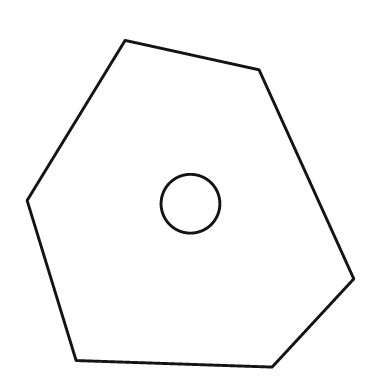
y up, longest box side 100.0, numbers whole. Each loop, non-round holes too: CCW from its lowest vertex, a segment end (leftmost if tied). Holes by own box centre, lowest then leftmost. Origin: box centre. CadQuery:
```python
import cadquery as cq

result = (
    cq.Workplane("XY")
    .moveTo(25.0, -50.0)
    .lineTo(50.0, -23.0)
    .lineTo(21.0, 41.0)
    .lineTo(-20.0, 50.0)
    .lineTo(-50.0, 1.0)
    .lineTo(-35.0, -48.0)
    .close()
    .moveTo(0.0, 0.0)
    .circle(9.0)
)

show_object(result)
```